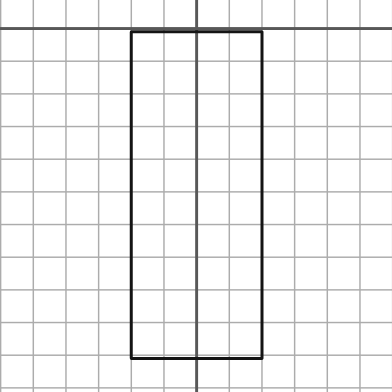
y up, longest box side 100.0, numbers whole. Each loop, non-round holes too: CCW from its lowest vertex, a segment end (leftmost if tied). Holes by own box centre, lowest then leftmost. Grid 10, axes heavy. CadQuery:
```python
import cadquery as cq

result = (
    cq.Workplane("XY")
    .moveTo(-20.0, -101.0)
    .lineTo(20.0, -101.0)
    .lineTo(20.0, -1.0)
    .lineTo(-20.0, -1.0)
    .close()
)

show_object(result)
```